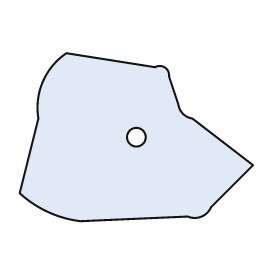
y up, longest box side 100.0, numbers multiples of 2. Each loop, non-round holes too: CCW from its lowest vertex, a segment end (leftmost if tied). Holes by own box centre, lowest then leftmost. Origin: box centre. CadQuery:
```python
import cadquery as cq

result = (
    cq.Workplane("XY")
    .moveTo(-24.0, -36.0)
    .lineTo(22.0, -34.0)
    .threePointArc((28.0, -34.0), (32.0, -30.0))
    .lineTo(50.0, -12.0)
    .lineTo(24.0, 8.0)
    .threePointArc((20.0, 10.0), (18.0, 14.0))
    .lineTo(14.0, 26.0)
    .threePointArc((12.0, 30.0), (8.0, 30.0))
    .lineTo(-30.0, 36.0)
    .threePointArc((-40.0, 24.0), (-42.0, 8.0))
    .lineTo(-50.0, -24.0)
    .threePointArc((-38.0, -32.0), (-24.0, -36.0))
    .close()
    .moveTo(0.0, 0.0)
    .circle(4.0)
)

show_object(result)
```